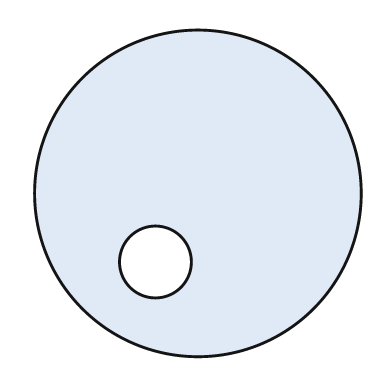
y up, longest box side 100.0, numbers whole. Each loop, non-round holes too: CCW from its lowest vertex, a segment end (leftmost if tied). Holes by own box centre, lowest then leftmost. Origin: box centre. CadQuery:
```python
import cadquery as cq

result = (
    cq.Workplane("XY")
    .moveTo(0.0, 0.0)
    .circle(50.0)
    .moveTo(-13.0, -21.0)
    .circle(11.0)
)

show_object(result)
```